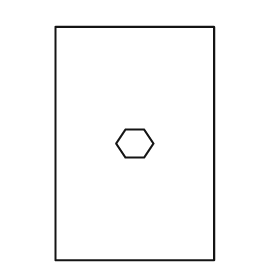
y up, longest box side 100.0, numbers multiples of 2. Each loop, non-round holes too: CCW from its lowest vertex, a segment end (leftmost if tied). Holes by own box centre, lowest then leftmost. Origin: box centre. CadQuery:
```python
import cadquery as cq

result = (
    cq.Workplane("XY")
    .moveTo(-34.0, -50.0)
    .lineTo(34.0, -50.0)
    .lineTo(34.0, 50.0)
    .lineTo(-34.0, 50.0)
    .close()
    .moveTo(-4.0, -6.0)
    .lineTo(4.0, -6.0)
    .lineTo(8.0, 0.0)
    .lineTo(4.0, 6.0)
    .lineTo(-4.0, 6.0)
    .lineTo(-8.0, 0.0)
    .close()
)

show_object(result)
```